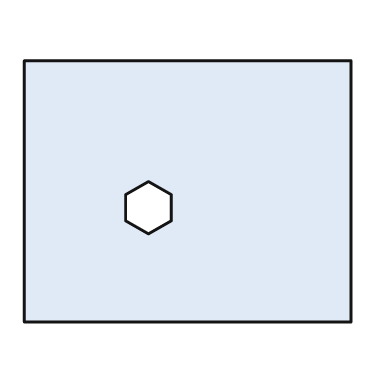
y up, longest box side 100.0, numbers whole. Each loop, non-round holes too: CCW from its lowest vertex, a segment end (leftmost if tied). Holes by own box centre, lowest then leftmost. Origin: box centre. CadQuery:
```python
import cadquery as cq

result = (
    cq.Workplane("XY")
    .moveTo(-50.0, -40.0)
    .lineTo(50.0, -40.0)
    .lineTo(50.0, 40.0)
    .lineTo(-50.0, 40.0)
    .close()
    .moveTo(-12.0, -13.0)
    .lineTo(-5.0, -9.0)
    .lineTo(-5.0, -1.0)
    .lineTo(-12.0, 3.0)
    .lineTo(-19.0, -1.0)
    .lineTo(-19.0, -9.0)
    .close()
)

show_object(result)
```